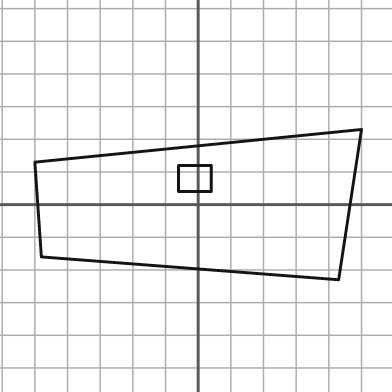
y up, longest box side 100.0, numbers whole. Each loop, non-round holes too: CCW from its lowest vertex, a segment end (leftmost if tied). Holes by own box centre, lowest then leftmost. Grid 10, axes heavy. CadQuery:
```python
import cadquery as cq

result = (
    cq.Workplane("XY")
    .moveTo(43.0, -23.0)
    .lineTo(50.0, 23.0)
    .lineTo(-50.0, 13.0)
    .lineTo(-48.0, -16.0)
    .close()
    .moveTo(-6.0, 4.0)
    .lineTo(4.0, 4.0)
    .lineTo(4.0, 12.0)
    .lineTo(-6.0, 12.0)
    .close()
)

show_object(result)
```